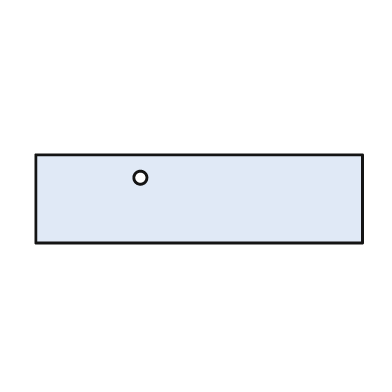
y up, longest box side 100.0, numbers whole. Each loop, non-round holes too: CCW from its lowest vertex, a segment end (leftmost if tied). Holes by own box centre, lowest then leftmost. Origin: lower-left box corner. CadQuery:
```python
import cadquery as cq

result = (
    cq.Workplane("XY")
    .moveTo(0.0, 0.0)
    .lineTo(100.0, 0.0)
    .lineTo(100.0, 27.0)
    .lineTo(0.0, 27.0)
    .close()
    .moveTo(32.0, 20.0)
    .circle(2.0)
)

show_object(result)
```